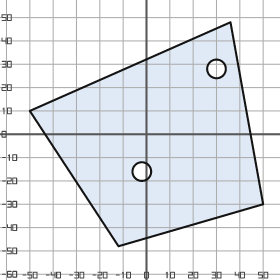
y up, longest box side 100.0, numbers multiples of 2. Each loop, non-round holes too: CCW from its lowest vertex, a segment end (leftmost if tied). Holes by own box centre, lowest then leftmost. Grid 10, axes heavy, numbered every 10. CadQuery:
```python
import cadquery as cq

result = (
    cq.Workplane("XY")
    .moveTo(-12.0, -48.0)
    .lineTo(50.0, -30.0)
    .lineTo(36.0, 48.0)
    .lineTo(-50.0, 10.0)
    .close()
    .moveTo(-2.0, -16.0)
    .circle(4.0)
    .moveTo(30.0, 28.0)
    .circle(4.0)
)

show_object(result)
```